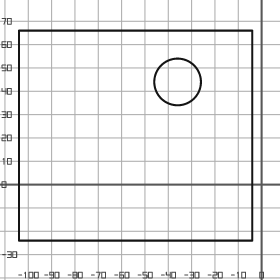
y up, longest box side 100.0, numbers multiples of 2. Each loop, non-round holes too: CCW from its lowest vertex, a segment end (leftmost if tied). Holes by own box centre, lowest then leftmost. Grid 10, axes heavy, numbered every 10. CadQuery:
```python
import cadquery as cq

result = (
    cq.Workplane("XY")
    .moveTo(-104.0, -24.0)
    .lineTo(-4.0, -24.0)
    .lineTo(-4.0, 66.0)
    .lineTo(-104.0, 66.0)
    .close()
    .moveTo(-36.0, 44.0)
    .circle(10.0)
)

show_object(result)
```